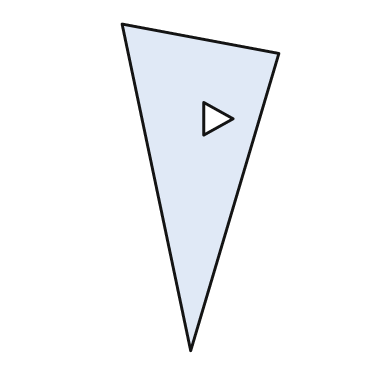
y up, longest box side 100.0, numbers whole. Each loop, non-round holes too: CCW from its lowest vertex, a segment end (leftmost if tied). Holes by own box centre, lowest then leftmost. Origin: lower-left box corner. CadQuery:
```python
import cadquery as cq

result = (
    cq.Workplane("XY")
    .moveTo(21.0, 0.0)
    .lineTo(48.0, 91.0)
    .lineTo(0.0, 100.0)
    .close()
    .moveTo(25.0, 66.0)
    .lineTo(34.0, 71.0)
    .lineTo(25.0, 76.0)
    .close()
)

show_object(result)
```